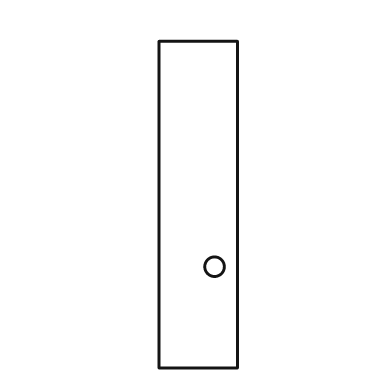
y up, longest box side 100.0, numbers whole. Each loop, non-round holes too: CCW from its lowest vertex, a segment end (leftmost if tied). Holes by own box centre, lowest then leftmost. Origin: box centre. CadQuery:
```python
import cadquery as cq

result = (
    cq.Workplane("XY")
    .moveTo(-12.0, -50.0)
    .lineTo(12.0, -50.0)
    .lineTo(12.0, 50.0)
    .lineTo(-12.0, 50.0)
    .close()
    .moveTo(5.0, -19.0)
    .circle(3.0)
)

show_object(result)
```